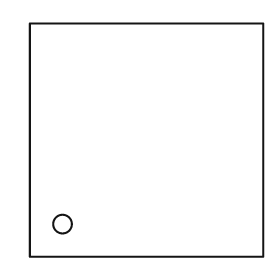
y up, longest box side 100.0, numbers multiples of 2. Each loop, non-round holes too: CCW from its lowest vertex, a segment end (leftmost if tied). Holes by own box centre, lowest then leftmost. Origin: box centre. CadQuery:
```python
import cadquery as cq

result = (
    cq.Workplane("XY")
    .moveTo(-50.0, -50.0)
    .lineTo(50.0, -50.0)
    .lineTo(50.0, 50.0)
    .lineTo(-50.0, 50.0)
    .close()
    .moveTo(-36.0, -36.0)
    .circle(4.0)
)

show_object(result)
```